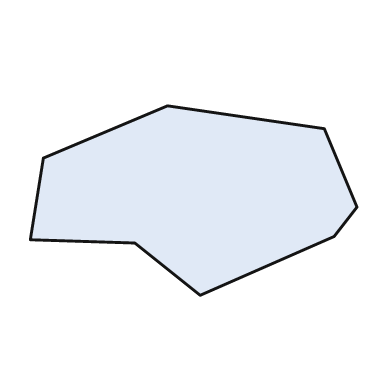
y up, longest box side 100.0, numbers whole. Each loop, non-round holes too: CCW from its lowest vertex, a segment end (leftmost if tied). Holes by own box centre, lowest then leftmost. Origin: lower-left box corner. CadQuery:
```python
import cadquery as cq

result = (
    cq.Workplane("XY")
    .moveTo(52.0, 0.0)
    .lineTo(93.0, 18.0)
    .lineTo(100.0, 27.0)
    .lineTo(90.0, 51.0)
    .lineTo(42.0, 58.0)
    .lineTo(4.0, 42.0)
    .lineTo(0.0, 17.0)
    .lineTo(32.0, 16.0)
    .close()
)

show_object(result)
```